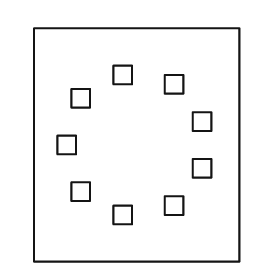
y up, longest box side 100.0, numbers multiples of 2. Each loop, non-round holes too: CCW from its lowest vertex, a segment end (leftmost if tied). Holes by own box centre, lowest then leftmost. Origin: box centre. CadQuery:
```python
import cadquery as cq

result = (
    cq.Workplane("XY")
    .moveTo(-44.0, -50.0)
    .lineTo(44.0, -50.0)
    .lineTo(44.0, 50.0)
    .lineTo(-44.0, 50.0)
    .close()
    .moveTo(-10.0, -34.0)
    .lineTo(-2.0, -34.0)
    .lineTo(-2.0, -26.0)
    .lineTo(-10.0, -26.0)
    .close()
    .moveTo(12.0, -30.0)
    .lineTo(20.0, -30.0)
    .lineTo(20.0, -22.0)
    .lineTo(12.0, -22.0)
    .close()
    .moveTo(-28.0, -24.0)
    .lineTo(-20.0, -24.0)
    .lineTo(-20.0, -16.0)
    .lineTo(-28.0, -16.0)
    .close()
    .moveTo(24.0, -14.0)
    .lineTo(32.0, -14.0)
    .lineTo(32.0, -6.0)
    .lineTo(24.0, -6.0)
    .close()
    .moveTo(-34.0, -4.0)
    .lineTo(-26.0, -4.0)
    .lineTo(-26.0, 4.0)
    .lineTo(-34.0, 4.0)
    .close()
    .moveTo(24.0, 6.0)
    .lineTo(32.0, 6.0)
    .lineTo(32.0, 14.0)
    .lineTo(24.0, 14.0)
    .close()
    .moveTo(-28.0, 16.0)
    .lineTo(-20.0, 16.0)
    .lineTo(-20.0, 24.0)
    .lineTo(-28.0, 24.0)
    .close()
    .moveTo(12.0, 22.0)
    .lineTo(20.0, 22.0)
    .lineTo(20.0, 30.0)
    .lineTo(12.0, 30.0)
    .close()
    .moveTo(-10.0, 26.0)
    .lineTo(-2.0, 26.0)
    .lineTo(-2.0, 34.0)
    .lineTo(-10.0, 34.0)
    .close()
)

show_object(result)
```